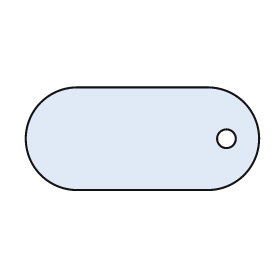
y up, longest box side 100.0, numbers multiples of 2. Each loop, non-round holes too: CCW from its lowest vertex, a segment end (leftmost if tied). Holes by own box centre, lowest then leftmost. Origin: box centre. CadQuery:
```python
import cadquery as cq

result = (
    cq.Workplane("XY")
    .moveTo(-28.0, -22.0)
    .lineTo(28.0, -22.0)
    .threePointArc((50.0, 0.0), (28.0, 22.0))
    .lineTo(-28.0, 22.0)
    .threePointArc((-50.0, 0.0), (-28.0, -22.0))
    .close()
    .moveTo(36.0, 0.0)
    .circle(4.0)
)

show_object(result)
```